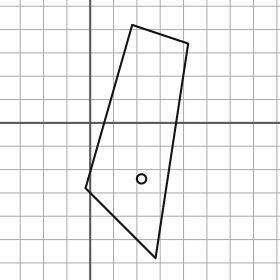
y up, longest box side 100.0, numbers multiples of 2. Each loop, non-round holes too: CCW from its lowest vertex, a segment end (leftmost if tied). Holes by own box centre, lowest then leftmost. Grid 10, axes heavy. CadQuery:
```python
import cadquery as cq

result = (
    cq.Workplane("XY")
    .moveTo(28.0, -58.0)
    .lineTo(42.0, 34.0)
    .lineTo(18.0, 42.0)
    .lineTo(-2.0, -28.0)
    .close()
    .moveTo(22.0, -24.0)
    .circle(2.0)
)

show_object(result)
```